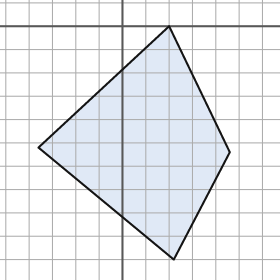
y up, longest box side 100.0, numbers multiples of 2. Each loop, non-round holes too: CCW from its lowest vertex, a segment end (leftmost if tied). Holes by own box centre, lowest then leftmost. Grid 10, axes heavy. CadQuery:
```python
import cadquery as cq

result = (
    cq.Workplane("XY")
    .moveTo(22.0, -100.0)
    .lineTo(46.0, -54.0)
    .lineTo(20.0, 0.0)
    .lineTo(-36.0, -52.0)
    .close()
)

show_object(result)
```